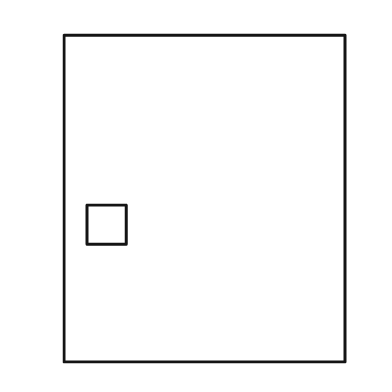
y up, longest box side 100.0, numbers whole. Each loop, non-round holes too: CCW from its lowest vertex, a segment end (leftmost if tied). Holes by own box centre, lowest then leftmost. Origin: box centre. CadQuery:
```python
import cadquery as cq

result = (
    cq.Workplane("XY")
    .moveTo(-43.0, -50.0)
    .lineTo(43.0, -50.0)
    .lineTo(43.0, 50.0)
    .lineTo(-43.0, 50.0)
    .close()
    .moveTo(-36.0, -14.0)
    .lineTo(-24.0, -14.0)
    .lineTo(-24.0, -2.0)
    .lineTo(-36.0, -2.0)
    .close()
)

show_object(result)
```